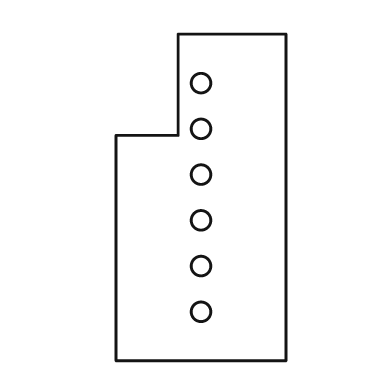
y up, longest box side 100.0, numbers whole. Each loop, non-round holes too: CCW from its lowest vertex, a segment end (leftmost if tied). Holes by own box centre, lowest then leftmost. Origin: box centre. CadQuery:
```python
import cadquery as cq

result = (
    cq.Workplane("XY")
    .moveTo(-26.0, -50.0)
    .lineTo(26.0, -50.0)
    .lineTo(26.0, 50.0)
    .lineTo(-7.0, 50.0)
    .lineTo(-7.0, 19.0)
    .lineTo(-26.0, 19.0)
    .close()
    .moveTo(0.0, -35.0)
    .circle(3.0)
    .moveTo(0.0, -21.0)
    .circle(3.0)
    .moveTo(0.0, -7.0)
    .circle(3.0)
    .moveTo(0.0, 7.0)
    .circle(3.0)
    .moveTo(0.0, 21.0)
    .circle(3.0)
    .moveTo(0.0, 35.0)
    .circle(3.0)
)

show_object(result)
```